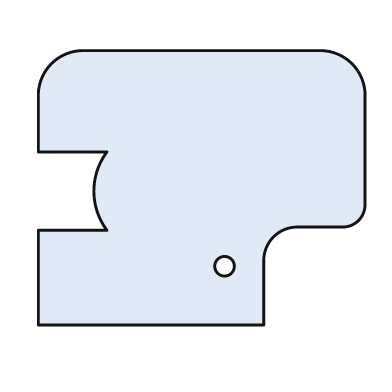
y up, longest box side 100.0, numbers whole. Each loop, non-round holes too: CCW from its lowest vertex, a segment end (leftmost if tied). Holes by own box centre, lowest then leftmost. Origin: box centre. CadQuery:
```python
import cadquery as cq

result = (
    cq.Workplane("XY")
    .moveTo(-50.0, -42.0)
    .lineTo(19.0, -42.0)
    .lineTo(19.0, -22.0)
    .threePointArc((22.0, -15.0), (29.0, -12.0))
    .lineTo(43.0, -12.0)
    .threePointArc((48.0, -10.0), (50.0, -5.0))
    .lineTo(50.0, 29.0)
    .threePointArc((46.0, 38.0), (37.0, 42.0))
    .lineTo(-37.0, 42.0)
    .threePointArc((-46.0, 38.0), (-50.0, 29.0))
    .lineTo(-50.0, 11.0)
    .lineTo(-29.0, 11.0)
    .threePointArc((-33.0, -1.0), (-29.0, -13.0))
    .lineTo(-50.0, -13.0)
    .close()
    .moveTo(7.0, -24.0)
    .circle(3.0)
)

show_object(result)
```